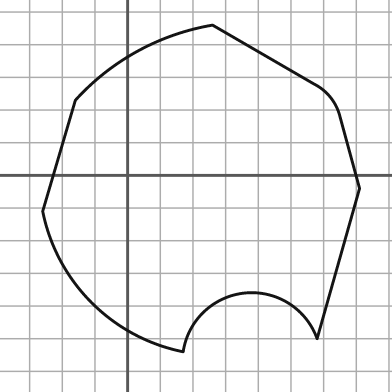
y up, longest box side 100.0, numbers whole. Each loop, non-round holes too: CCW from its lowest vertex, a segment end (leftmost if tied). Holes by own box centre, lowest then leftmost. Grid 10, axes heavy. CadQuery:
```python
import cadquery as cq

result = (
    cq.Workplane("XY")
    .moveTo(17.0, -54.0)
    .threePointArc((36.0, -36.0), (58.0, -50.0))
    .lineTo(71.0, -4.0)
    .lineTo(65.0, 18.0)
    .threePointArc((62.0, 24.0), (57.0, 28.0))
    .lineTo(26.0, 46.0)
    .threePointArc((3.0, 38.0), (-16.0, 23.0))
    .lineTo(-26.0, -11.0)
    .threePointArc((-11.0, -39.0), (17.0, -54.0))
    .close()
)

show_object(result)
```